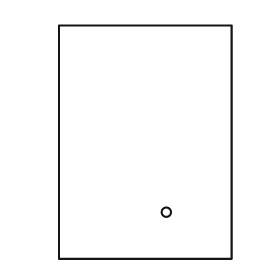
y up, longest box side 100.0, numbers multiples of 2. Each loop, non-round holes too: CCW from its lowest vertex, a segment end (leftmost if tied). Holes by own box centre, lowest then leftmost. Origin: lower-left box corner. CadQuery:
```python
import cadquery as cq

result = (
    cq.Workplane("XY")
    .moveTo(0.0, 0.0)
    .lineTo(74.0, 0.0)
    .lineTo(74.0, 100.0)
    .lineTo(0.0, 100.0)
    .close()
    .moveTo(46.0, 20.0)
    .circle(2.0)
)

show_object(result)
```